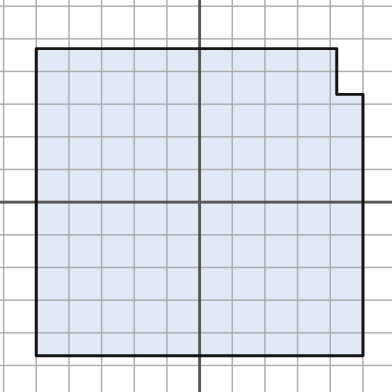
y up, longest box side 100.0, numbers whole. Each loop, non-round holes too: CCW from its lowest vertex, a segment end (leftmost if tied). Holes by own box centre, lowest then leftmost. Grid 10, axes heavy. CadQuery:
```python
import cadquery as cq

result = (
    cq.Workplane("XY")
    .moveTo(-50.0, -47.0)
    .lineTo(50.0, -47.0)
    .lineTo(50.0, 33.0)
    .lineTo(42.0, 33.0)
    .lineTo(42.0, 47.0)
    .lineTo(-50.0, 47.0)
    .close()
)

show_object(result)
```